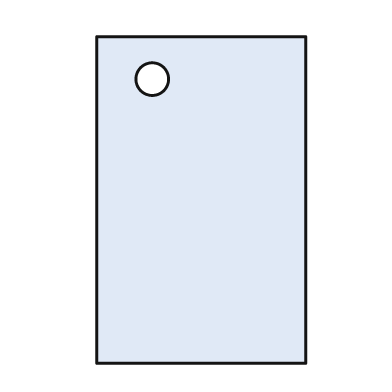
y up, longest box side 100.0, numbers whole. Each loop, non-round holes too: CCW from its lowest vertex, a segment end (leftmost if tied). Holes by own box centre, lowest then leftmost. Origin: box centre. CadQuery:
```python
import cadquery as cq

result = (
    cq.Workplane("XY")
    .moveTo(-32.0, -50.0)
    .lineTo(32.0, -50.0)
    .lineTo(32.0, 50.0)
    .lineTo(-32.0, 50.0)
    .close()
    .moveTo(-15.0, 37.0)
    .circle(5.0)
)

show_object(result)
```